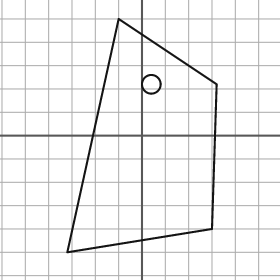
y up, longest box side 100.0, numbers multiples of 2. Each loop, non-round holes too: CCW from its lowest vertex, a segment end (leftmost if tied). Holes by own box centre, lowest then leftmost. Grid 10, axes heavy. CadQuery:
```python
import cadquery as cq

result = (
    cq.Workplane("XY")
    .moveTo(-32.0, -50.0)
    .lineTo(30.0, -40.0)
    .lineTo(32.0, 22.0)
    .lineTo(-10.0, 50.0)
    .close()
    .moveTo(4.0, 22.0)
    .circle(4.0)
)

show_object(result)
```